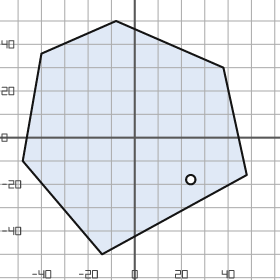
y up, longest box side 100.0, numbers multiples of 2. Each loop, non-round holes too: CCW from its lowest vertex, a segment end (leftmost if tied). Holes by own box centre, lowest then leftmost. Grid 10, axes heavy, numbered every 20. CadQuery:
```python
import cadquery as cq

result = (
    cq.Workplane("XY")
    .moveTo(-14.0, -50.0)
    .lineTo(48.0, -16.0)
    .lineTo(38.0, 30.0)
    .lineTo(-8.0, 50.0)
    .lineTo(-40.0, 36.0)
    .lineTo(-48.0, -10.0)
    .close()
    .moveTo(24.0, -18.0)
    .circle(2.0)
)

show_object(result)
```